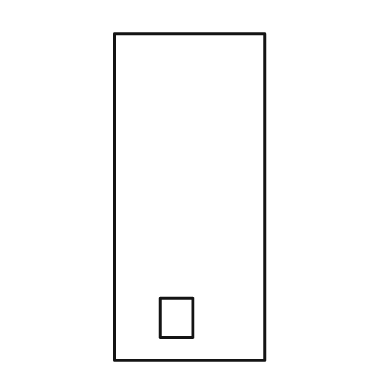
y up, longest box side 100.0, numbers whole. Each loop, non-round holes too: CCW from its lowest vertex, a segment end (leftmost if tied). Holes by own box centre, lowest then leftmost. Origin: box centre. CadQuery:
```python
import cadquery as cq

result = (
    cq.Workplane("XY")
    .moveTo(-23.0, -50.0)
    .lineTo(23.0, -50.0)
    .lineTo(23.0, 50.0)
    .lineTo(-23.0, 50.0)
    .close()
    .moveTo(-9.0, -43.0)
    .lineTo(1.0, -43.0)
    .lineTo(1.0, -31.0)
    .lineTo(-9.0, -31.0)
    .close()
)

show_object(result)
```